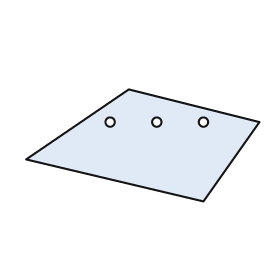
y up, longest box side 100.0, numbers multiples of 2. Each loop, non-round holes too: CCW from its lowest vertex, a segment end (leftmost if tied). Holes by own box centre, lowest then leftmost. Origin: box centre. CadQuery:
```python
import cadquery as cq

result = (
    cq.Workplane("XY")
    .moveTo(26.0, -24.0)
    .lineTo(50.0, 10.0)
    .lineTo(-6.0, 24.0)
    .lineTo(-50.0, -6.0)
    .close()
    .moveTo(-14.0, 10.0)
    .circle(2.0)
    .moveTo(6.0, 10.0)
    .circle(2.0)
    .moveTo(26.0, 10.0)
    .circle(2.0)
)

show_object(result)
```